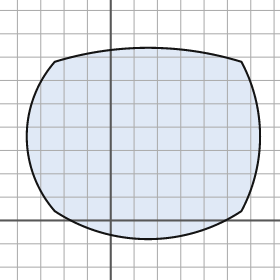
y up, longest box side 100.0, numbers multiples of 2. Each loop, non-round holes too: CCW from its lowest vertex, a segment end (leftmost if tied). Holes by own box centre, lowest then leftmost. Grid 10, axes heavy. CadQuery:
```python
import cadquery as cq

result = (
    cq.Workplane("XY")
    .moveTo(-24.0, 4.0)
    .threePointArc((16.0, -8.0), (56.0, 4.0))
    .threePointArc((64.0, 36.0), (56.0, 68.0))
    .threePointArc((16.0, 74.0), (-24.0, 68.0))
    .threePointArc((-36.0, 36.0), (-24.0, 4.0))
    .close()
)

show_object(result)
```